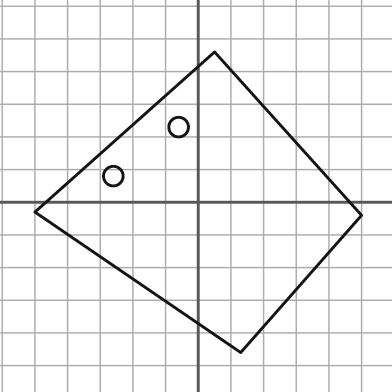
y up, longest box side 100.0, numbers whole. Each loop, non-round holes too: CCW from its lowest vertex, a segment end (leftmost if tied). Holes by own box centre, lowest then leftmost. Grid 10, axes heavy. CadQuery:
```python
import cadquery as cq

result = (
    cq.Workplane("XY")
    .moveTo(13.0, -46.0)
    .lineTo(50.0, -4.0)
    .lineTo(5.0, 46.0)
    .lineTo(-50.0, -3.0)
    .close()
    .moveTo(-26.0, 8.0)
    .circle(3.0)
    .moveTo(-6.0, 23.0)
    .circle(3.0)
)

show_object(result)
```